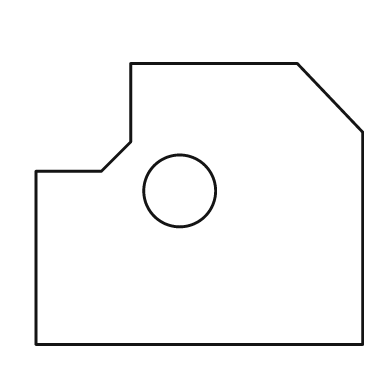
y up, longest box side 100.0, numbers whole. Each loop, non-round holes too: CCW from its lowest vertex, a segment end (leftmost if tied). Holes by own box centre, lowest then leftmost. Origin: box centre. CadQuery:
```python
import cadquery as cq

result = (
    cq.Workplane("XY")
    .moveTo(-50.0, -43.0)
    .lineTo(50.0, -43.0)
    .lineTo(50.0, 22.0)
    .lineTo(30.0, 43.0)
    .lineTo(-21.0, 43.0)
    .lineTo(-21.0, 19.0)
    .lineTo(-30.0, 10.0)
    .lineTo(-50.0, 10.0)
    .close()
    .moveTo(-6.0, 4.0)
    .circle(11.0)
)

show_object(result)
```